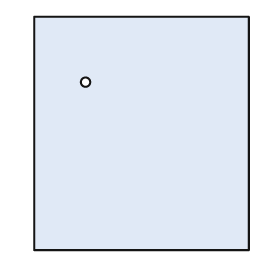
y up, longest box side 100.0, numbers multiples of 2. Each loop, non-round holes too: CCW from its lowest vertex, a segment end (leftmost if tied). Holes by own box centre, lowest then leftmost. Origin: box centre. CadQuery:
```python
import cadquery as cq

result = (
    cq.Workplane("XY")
    .moveTo(-46.0, -50.0)
    .lineTo(46.0, -50.0)
    .lineTo(46.0, 50.0)
    .lineTo(-46.0, 50.0)
    .close()
    .moveTo(-24.0, 22.0)
    .circle(2.0)
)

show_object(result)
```